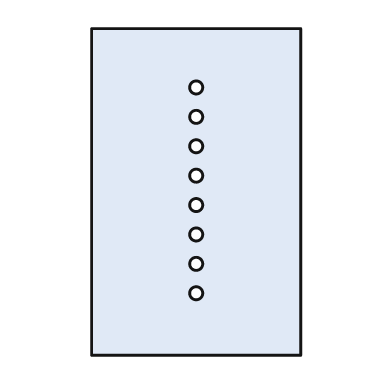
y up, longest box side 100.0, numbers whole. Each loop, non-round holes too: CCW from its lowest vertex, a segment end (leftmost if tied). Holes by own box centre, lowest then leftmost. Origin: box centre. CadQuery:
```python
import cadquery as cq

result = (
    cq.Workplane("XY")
    .moveTo(-32.0, -50.0)
    .lineTo(32.0, -50.0)
    .lineTo(32.0, 50.0)
    .lineTo(-32.0, 50.0)
    .close()
    .moveTo(0.0, -31.0)
    .circle(2.0)
    .moveTo(0.0, -22.0)
    .circle(2.0)
    .moveTo(0.0, -13.0)
    .circle(2.0)
    .moveTo(0.0, -4.0)
    .circle(2.0)
    .moveTo(0.0, 5.0)
    .circle(2.0)
    .moveTo(0.0, 14.0)
    .circle(2.0)
    .moveTo(0.0, 23.0)
    .circle(2.0)
    .moveTo(0.0, 32.0)
    .circle(2.0)
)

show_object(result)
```